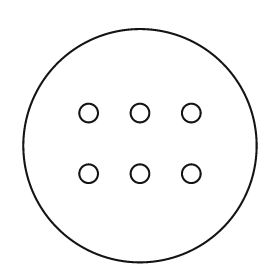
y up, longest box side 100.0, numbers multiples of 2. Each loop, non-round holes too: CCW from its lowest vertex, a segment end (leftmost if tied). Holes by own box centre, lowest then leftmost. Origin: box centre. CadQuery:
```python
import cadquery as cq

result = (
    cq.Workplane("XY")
    .moveTo(0.0, 0.0)
    .circle(50.0)
    .moveTo(-22.0, -12.0)
    .circle(4.0)
    .moveTo(0.0, -12.0)
    .circle(4.0)
    .moveTo(22.0, -12.0)
    .circle(4.0)
    .moveTo(-22.0, 14.0)
    .circle(4.0)
    .moveTo(0.0, 14.0)
    .circle(4.0)
    .moveTo(22.0, 14.0)
    .circle(4.0)
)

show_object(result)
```